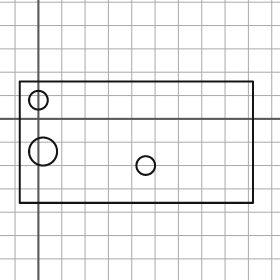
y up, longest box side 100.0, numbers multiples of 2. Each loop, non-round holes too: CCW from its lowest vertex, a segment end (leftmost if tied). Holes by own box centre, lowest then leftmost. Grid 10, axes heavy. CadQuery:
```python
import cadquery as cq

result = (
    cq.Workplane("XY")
    .moveTo(-8.0, -36.0)
    .lineTo(92.0, -36.0)
    .lineTo(92.0, 16.0)
    .lineTo(-8.0, 16.0)
    .close()
    .moveTo(46.0, -20.0)
    .circle(4.0)
    .moveTo(2.0, -14.0)
    .circle(6.0)
    .moveTo(0.0, 8.0)
    .circle(4.0)
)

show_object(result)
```